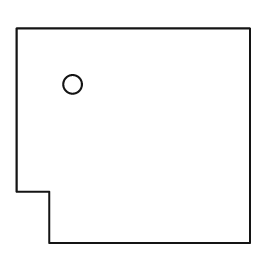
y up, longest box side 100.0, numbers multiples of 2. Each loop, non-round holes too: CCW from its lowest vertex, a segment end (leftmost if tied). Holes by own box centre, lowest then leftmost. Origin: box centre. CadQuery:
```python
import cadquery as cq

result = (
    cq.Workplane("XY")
    .moveTo(-36.0, -46.0)
    .lineTo(50.0, -46.0)
    .lineTo(50.0, 46.0)
    .lineTo(-50.0, 46.0)
    .lineTo(-50.0, -24.0)
    .lineTo(-36.0, -24.0)
    .close()
    .moveTo(-26.0, 22.0)
    .circle(4.0)
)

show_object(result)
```